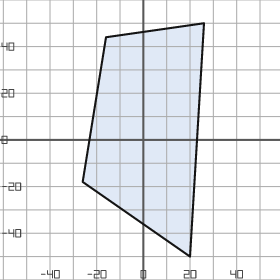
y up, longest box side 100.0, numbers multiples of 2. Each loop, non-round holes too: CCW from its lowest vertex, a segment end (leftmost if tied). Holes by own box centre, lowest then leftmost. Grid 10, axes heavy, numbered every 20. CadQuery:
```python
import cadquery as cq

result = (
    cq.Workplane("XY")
    .moveTo(20.0, -50.0)
    .lineTo(26.0, 50.0)
    .lineTo(-16.0, 44.0)
    .lineTo(-26.0, -18.0)
    .close()
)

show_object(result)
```